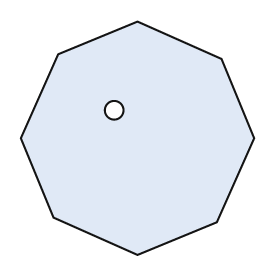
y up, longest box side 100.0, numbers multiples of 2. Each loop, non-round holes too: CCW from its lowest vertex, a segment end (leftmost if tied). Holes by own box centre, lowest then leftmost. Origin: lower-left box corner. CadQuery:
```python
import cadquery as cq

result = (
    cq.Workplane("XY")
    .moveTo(50.0, 0.0)
    .lineTo(84.0, 14.0)
    .lineTo(100.0, 50.0)
    .lineTo(86.0, 84.0)
    .lineTo(50.0, 100.0)
    .lineTo(16.0, 86.0)
    .lineTo(0.0, 50.0)
    .lineTo(14.0, 16.0)
    .close()
    .moveTo(40.0, 62.0)
    .circle(4.0)
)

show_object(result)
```